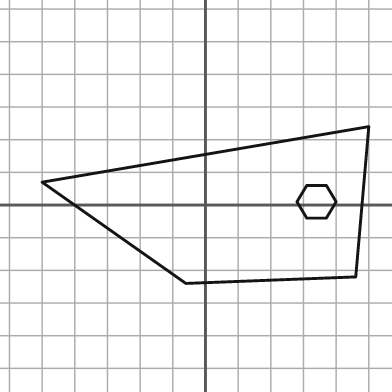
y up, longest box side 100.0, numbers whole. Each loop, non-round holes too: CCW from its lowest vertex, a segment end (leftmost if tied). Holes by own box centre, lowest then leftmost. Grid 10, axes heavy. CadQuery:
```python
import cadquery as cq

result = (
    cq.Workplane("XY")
    .moveTo(-6.0, -24.0)
    .lineTo(46.0, -22.0)
    .lineTo(50.0, 24.0)
    .lineTo(-50.0, 7.0)
    .close()
    .moveTo(31.0, -4.0)
    .lineTo(37.0, -4.0)
    .lineTo(40.0, 1.0)
    .lineTo(37.0, 6.0)
    .lineTo(31.0, 6.0)
    .lineTo(28.0, 1.0)
    .close()
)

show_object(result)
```